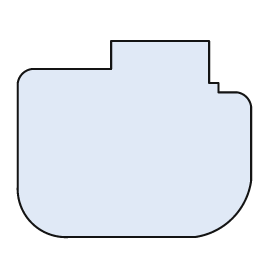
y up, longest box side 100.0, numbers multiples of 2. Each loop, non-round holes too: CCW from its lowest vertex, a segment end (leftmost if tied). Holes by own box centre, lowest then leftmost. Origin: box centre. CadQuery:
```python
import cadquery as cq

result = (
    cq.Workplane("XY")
    .moveTo(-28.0, -42.0)
    .lineTo(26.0, -42.0)
    .threePointArc((42.0, -34.0), (50.0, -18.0))
    .lineTo(50.0, 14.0)
    .threePointArc((48.0, 18.0), (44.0, 20.0))
    .lineTo(36.0, 20.0)
    .lineTo(36.0, 24.0)
    .lineTo(32.0, 24.0)
    .lineTo(32.0, 42.0)
    .lineTo(-10.0, 42.0)
    .lineTo(-10.0, 30.0)
    .lineTo(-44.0, 30.0)
    .threePointArc((-48.0, 28.0), (-50.0, 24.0))
    .lineTo(-50.0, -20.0)
    .threePointArc((-44.0, -36.0), (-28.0, -42.0))
    .close()
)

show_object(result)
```